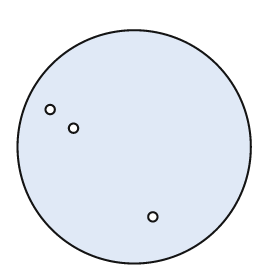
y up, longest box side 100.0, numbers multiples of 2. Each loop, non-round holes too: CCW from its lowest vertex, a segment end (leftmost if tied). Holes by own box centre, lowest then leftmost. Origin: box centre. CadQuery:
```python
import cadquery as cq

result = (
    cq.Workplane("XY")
    .moveTo(0.0, 0.0)
    .circle(50.0)
    .moveTo(8.0, -30.0)
    .circle(2.0)
    .moveTo(-26.0, 8.0)
    .circle(2.0)
    .moveTo(-36.0, 16.0)
    .circle(2.0)
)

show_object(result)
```